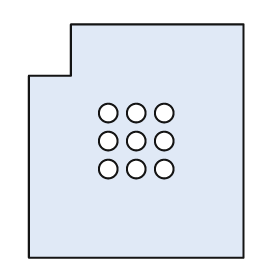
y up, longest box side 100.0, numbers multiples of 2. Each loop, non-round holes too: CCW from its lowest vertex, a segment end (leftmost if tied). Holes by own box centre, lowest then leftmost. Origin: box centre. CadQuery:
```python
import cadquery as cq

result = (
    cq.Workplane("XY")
    .moveTo(-46.0, -50.0)
    .lineTo(46.0, -50.0)
    .lineTo(46.0, 50.0)
    .lineTo(-28.0, 50.0)
    .lineTo(-28.0, 28.0)
    .lineTo(-46.0, 28.0)
    .close()
    .moveTo(-12.0, -12.0)
    .circle(4.0)
    .moveTo(0.0, -12.0)
    .circle(4.0)
    .moveTo(12.0, -12.0)
    .circle(4.0)
    .moveTo(-12.0, 0.0)
    .circle(4.0)
    .moveTo(0.0, 0.0)
    .circle(4.0)
    .moveTo(12.0, 0.0)
    .circle(4.0)
    .moveTo(-12.0, 12.0)
    .circle(4.0)
    .moveTo(0.0, 12.0)
    .circle(4.0)
    .moveTo(12.0, 12.0)
    .circle(4.0)
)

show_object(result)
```